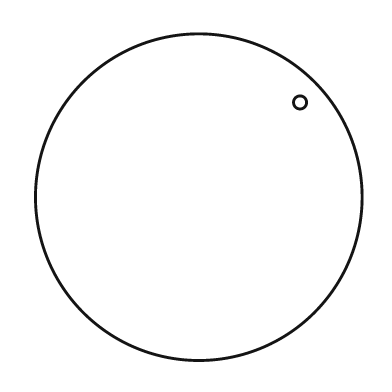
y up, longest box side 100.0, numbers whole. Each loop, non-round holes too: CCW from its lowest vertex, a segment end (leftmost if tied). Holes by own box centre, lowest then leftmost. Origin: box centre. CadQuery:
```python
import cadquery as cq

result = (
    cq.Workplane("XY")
    .moveTo(0.0, 0.0)
    .circle(50.0)
    .moveTo(31.0, 29.0)
    .circle(2.0)
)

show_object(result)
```